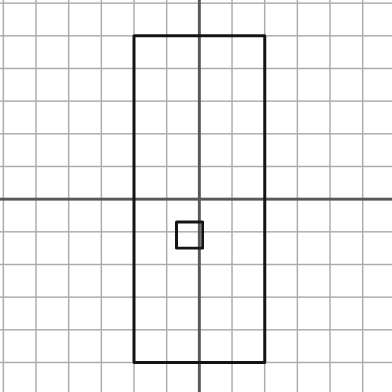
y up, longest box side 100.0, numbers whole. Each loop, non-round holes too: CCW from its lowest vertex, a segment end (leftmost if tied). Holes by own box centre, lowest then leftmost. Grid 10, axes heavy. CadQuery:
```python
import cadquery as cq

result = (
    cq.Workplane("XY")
    .moveTo(-20.0, -50.0)
    .lineTo(20.0, -50.0)
    .lineTo(20.0, 50.0)
    .lineTo(-20.0, 50.0)
    .close()
    .moveTo(-7.0, -15.0)
    .lineTo(1.0, -15.0)
    .lineTo(1.0, -7.0)
    .lineTo(-7.0, -7.0)
    .close()
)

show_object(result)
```